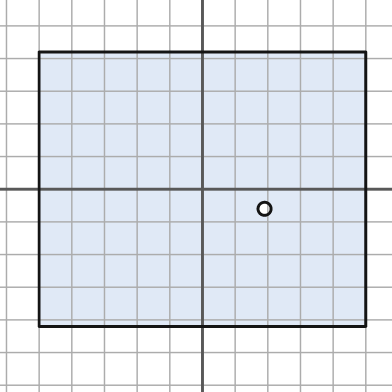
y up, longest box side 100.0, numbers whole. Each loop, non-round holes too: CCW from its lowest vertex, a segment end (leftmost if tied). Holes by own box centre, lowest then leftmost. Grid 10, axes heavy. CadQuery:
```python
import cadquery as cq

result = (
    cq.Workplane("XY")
    .moveTo(-50.0, -42.0)
    .lineTo(50.0, -42.0)
    .lineTo(50.0, 42.0)
    .lineTo(-50.0, 42.0)
    .close()
    .moveTo(19.0, -6.0)
    .circle(2.0)
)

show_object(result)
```